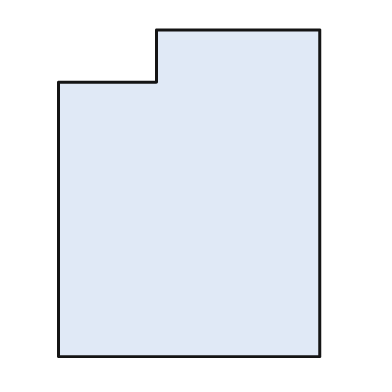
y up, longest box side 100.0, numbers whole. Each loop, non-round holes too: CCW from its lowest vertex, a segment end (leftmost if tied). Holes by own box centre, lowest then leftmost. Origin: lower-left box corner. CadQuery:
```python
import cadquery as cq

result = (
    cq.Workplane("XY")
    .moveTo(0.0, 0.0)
    .lineTo(80.0, 0.0)
    .lineTo(80.0, 100.0)
    .lineTo(30.0, 100.0)
    .lineTo(30.0, 84.0)
    .lineTo(0.0, 84.0)
    .close()
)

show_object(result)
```